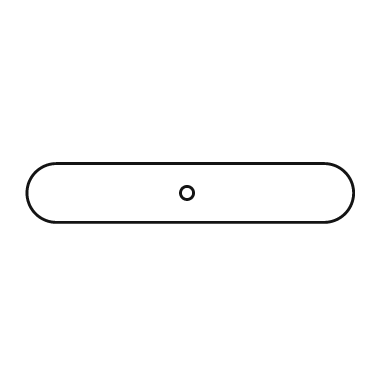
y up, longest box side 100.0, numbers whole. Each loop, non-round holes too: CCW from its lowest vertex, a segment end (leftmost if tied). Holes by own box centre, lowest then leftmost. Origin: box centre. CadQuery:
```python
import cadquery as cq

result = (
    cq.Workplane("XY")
    .moveTo(-41.0, -9.0)
    .lineTo(41.0, -9.0)
    .threePointArc((50.0, 0.0), (41.0, 9.0))
    .lineTo(-41.0, 9.0)
    .threePointArc((-50.0, 0.0), (-41.0, -9.0))
    .close()
    .moveTo(-1.0, 0.0)
    .circle(2.0)
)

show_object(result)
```